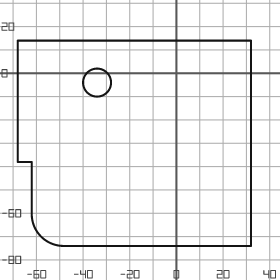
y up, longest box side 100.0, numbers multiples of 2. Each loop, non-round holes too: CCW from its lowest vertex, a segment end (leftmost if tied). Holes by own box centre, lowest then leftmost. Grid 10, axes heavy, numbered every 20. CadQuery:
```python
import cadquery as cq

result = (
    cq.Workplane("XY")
    .moveTo(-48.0, -74.0)
    .lineTo(32.0, -74.0)
    .lineTo(32.0, 14.0)
    .lineTo(-68.0, 14.0)
    .lineTo(-68.0, -38.0)
    .lineTo(-62.0, -38.0)
    .lineTo(-62.0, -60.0)
    .threePointArc((-58.0, -70.0), (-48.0, -74.0))
    .close()
    .moveTo(-34.0, -4.0)
    .circle(6.0)
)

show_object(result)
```